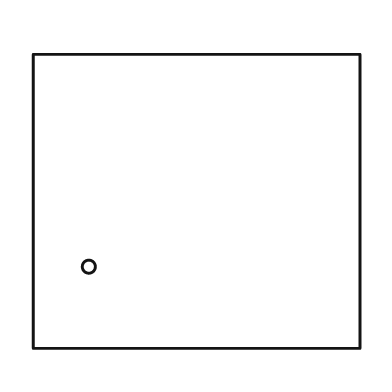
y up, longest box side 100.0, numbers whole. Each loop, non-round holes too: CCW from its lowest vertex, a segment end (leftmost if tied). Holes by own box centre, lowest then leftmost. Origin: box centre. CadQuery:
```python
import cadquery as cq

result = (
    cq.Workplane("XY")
    .moveTo(-50.0, -45.0)
    .lineTo(50.0, -45.0)
    .lineTo(50.0, 45.0)
    .lineTo(-50.0, 45.0)
    .close()
    .moveTo(-33.0, -20.0)
    .circle(2.0)
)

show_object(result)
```